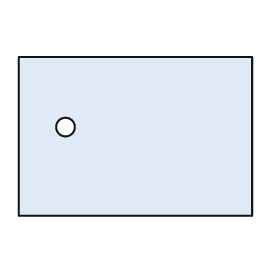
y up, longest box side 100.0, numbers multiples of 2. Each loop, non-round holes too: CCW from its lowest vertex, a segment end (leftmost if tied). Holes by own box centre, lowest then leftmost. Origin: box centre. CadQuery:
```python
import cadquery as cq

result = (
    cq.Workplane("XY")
    .moveTo(-50.0, -34.0)
    .lineTo(50.0, -34.0)
    .lineTo(50.0, 34.0)
    .lineTo(-50.0, 34.0)
    .close()
    .moveTo(-30.0, 4.0)
    .circle(4.0)
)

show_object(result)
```